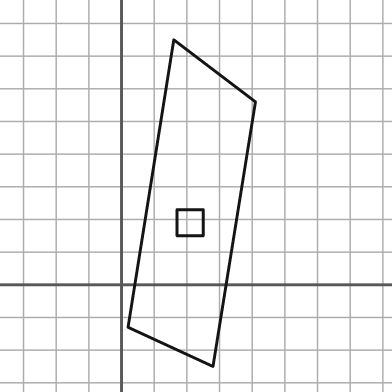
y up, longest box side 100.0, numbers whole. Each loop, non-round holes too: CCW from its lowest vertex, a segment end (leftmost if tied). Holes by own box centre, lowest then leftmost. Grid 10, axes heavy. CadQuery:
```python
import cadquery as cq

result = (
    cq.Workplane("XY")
    .moveTo(28.0, -25.0)
    .lineTo(41.0, 56.0)
    .lineTo(16.0, 75.0)
    .lineTo(2.0, -13.0)
    .close()
    .moveTo(17.0, 15.0)
    .lineTo(25.0, 15.0)
    .lineTo(25.0, 23.0)
    .lineTo(17.0, 23.0)
    .close()
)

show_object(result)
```